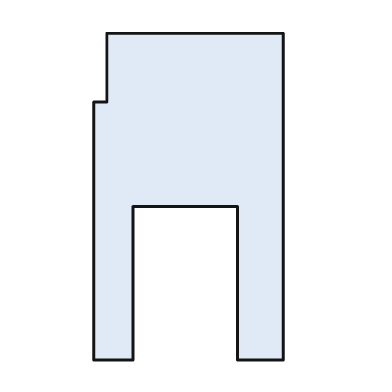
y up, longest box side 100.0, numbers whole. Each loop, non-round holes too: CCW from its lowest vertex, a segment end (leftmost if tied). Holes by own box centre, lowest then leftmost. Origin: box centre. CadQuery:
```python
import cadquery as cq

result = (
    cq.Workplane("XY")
    .moveTo(-29.0, -50.0)
    .lineTo(-17.0, -50.0)
    .lineTo(-17.0, -3.0)
    .lineTo(15.0, -3.0)
    .lineTo(15.0, -50.0)
    .lineTo(29.0, -50.0)
    .lineTo(29.0, 50.0)
    .lineTo(-25.0, 50.0)
    .lineTo(-25.0, 29.0)
    .lineTo(-29.0, 29.0)
    .close()
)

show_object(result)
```